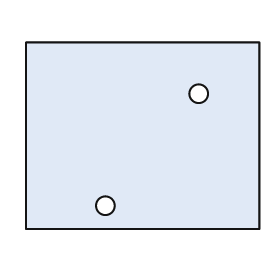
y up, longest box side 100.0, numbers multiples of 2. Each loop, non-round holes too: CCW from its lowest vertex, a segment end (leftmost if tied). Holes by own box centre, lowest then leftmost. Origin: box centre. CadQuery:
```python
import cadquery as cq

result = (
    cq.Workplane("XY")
    .moveTo(-50.0, -40.0)
    .lineTo(50.0, -40.0)
    .lineTo(50.0, 40.0)
    .lineTo(-50.0, 40.0)
    .close()
    .moveTo(-16.0, -30.0)
    .circle(4.0)
    .moveTo(24.0, 18.0)
    .circle(4.0)
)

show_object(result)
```